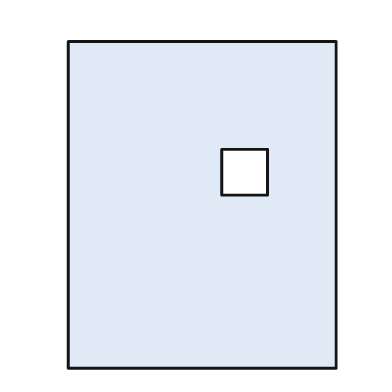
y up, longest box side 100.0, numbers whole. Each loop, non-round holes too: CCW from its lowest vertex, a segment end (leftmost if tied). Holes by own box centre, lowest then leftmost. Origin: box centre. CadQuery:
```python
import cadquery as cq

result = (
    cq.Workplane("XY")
    .moveTo(-41.0, -50.0)
    .lineTo(41.0, -50.0)
    .lineTo(41.0, 50.0)
    .lineTo(-41.0, 50.0)
    .close()
    .moveTo(6.0, 3.0)
    .lineTo(20.0, 3.0)
    .lineTo(20.0, 17.0)
    .lineTo(6.0, 17.0)
    .close()
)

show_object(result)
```